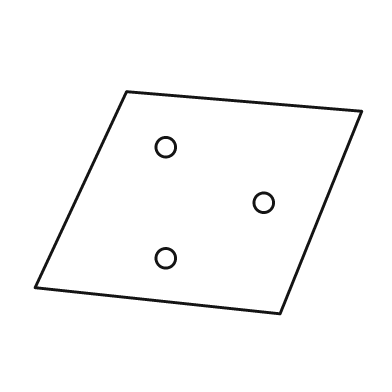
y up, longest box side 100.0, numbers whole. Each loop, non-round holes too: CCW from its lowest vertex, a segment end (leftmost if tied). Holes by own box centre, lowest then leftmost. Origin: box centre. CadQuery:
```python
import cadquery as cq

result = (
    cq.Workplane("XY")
    .moveTo(25.0, -34.0)
    .lineTo(50.0, 28.0)
    .lineTo(-22.0, 34.0)
    .lineTo(-50.0, -26.0)
    .close()
    .moveTo(-10.0, -17.0)
    .circle(3.0)
    .moveTo(20.0, 0.0)
    .circle(3.0)
    .moveTo(-10.0, 17.0)
    .circle(3.0)
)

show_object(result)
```